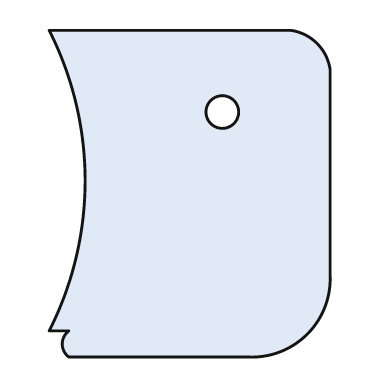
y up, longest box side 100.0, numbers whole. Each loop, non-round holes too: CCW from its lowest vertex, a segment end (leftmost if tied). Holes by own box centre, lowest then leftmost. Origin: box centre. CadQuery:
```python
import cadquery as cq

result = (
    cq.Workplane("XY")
    .moveTo(-37.0, -50.0)
    .lineTo(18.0, -50.0)
    .threePointArc((36.0, -43.0), (43.0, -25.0))
    .lineTo(43.0, 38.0)
    .threePointArc((39.0, 46.0), (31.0, 50.0))
    .lineTo(-43.0, 50.0)
    .threePointArc((-32.0, 4.0), (-43.0, -42.0))
    .lineTo(-37.0, -42.0)
    .threePointArc((-39.0, -46.0), (-37.0, -50.0))
    .close()
    .moveTo(10.0, 25.0)
    .circle(5.0)
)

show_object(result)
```